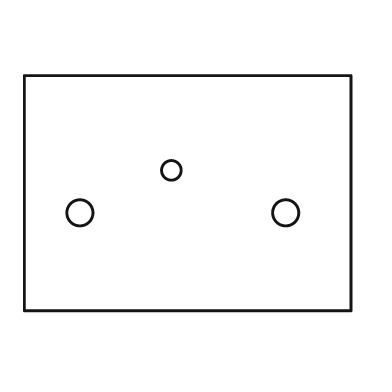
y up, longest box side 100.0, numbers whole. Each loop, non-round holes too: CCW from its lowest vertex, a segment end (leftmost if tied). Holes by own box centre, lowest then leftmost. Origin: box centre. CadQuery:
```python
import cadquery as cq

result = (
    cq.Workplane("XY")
    .moveTo(-50.0, -36.0)
    .lineTo(50.0, -36.0)
    .lineTo(50.0, 36.0)
    .lineTo(-50.0, 36.0)
    .close()
    .moveTo(-33.0, -6.0)
    .circle(4.0)
    .moveTo(30.0, -6.0)
    .circle(4.0)
    .moveTo(-5.0, 7.0)
    .circle(3.0)
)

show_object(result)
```